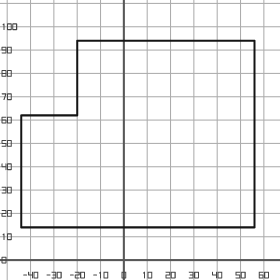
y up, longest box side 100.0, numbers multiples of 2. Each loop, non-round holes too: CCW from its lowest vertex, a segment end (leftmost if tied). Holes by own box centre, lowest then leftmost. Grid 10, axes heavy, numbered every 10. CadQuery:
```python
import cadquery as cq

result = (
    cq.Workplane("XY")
    .moveTo(-44.0, 14.0)
    .lineTo(56.0, 14.0)
    .lineTo(56.0, 94.0)
    .lineTo(-20.0, 94.0)
    .lineTo(-20.0, 62.0)
    .lineTo(-44.0, 62.0)
    .close()
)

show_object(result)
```